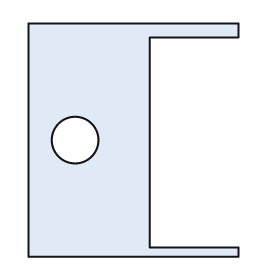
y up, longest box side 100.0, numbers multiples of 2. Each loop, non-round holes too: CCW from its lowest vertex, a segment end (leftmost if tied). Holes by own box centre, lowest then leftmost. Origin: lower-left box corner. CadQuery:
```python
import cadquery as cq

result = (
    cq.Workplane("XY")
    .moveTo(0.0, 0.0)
    .lineTo(90.0, 0.0)
    .lineTo(90.0, 4.0)
    .lineTo(52.0, 4.0)
    .lineTo(52.0, 94.0)
    .lineTo(90.0, 94.0)
    .lineTo(90.0, 100.0)
    .lineTo(0.0, 100.0)
    .close()
    .moveTo(20.0, 50.0)
    .circle(10.0)
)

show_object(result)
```